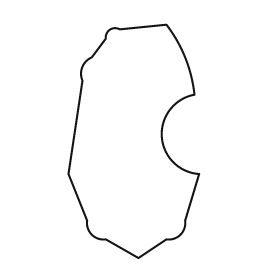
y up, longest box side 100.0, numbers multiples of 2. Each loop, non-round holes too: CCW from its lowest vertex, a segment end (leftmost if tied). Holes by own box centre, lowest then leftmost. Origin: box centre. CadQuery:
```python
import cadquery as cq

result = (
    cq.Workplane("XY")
    .moveTo(2.0, -50.0)
    .lineTo(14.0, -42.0)
    .threePointArc((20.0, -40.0), (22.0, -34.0))
    .lineTo(28.0, -14.0)
    .threePointArc((12.0, 2.0), (26.0, 20.0))
    .threePointArc((22.0, 36.0), (14.0, 50.0))
    .lineTo(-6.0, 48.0)
    .threePointArc((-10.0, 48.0), (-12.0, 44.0))
    .lineTo(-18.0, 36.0)
    .threePointArc((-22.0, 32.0), (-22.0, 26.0))
    .lineTo(-28.0, -14.0)
    .lineTo(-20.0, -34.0)
    .threePointArc((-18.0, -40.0), (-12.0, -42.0))
    .close()
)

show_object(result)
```